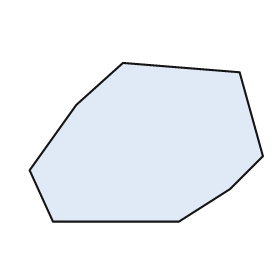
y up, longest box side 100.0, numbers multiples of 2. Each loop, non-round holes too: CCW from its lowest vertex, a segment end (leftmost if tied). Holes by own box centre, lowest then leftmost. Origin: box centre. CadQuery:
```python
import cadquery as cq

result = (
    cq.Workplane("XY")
    .moveTo(-40.0, -34.0)
    .lineTo(14.0, -34.0)
    .lineTo(36.0, -20.0)
    .lineTo(50.0, -6.0)
    .lineTo(40.0, 30.0)
    .lineTo(-10.0, 34.0)
    .lineTo(-30.0, 16.0)
    .lineTo(-50.0, -12.0)
    .close()
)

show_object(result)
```